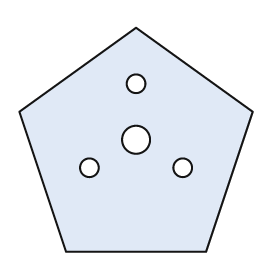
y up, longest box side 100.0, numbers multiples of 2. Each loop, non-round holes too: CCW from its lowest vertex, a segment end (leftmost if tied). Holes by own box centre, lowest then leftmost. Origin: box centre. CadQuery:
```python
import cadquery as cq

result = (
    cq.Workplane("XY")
    .moveTo(-30.0, -48.0)
    .lineTo(30.0, -48.0)
    .lineTo(50.0, 12.0)
    .lineTo(0.0, 48.0)
    .lineTo(-50.0, 12.0)
    .close()
    .moveTo(-20.0, -12.0)
    .circle(4.0)
    .moveTo(20.0, -12.0)
    .circle(4.0)
    .moveTo(0.0, 0.0)
    .circle(6.0)
    .moveTo(0.0, 24.0)
    .circle(4.0)
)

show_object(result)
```